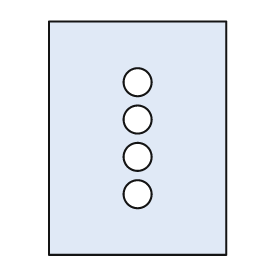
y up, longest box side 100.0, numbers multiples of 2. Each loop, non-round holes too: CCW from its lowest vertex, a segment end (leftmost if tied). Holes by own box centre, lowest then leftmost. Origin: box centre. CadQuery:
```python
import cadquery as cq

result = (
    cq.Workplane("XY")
    .moveTo(-38.0, -50.0)
    .lineTo(38.0, -50.0)
    .lineTo(38.0, 50.0)
    .lineTo(-38.0, 50.0)
    .close()
    .moveTo(0.0, -24.0)
    .circle(6.0)
    .moveTo(0.0, -8.0)
    .circle(6.0)
    .moveTo(0.0, 8.0)
    .circle(6.0)
    .moveTo(0.0, 24.0)
    .circle(6.0)
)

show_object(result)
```